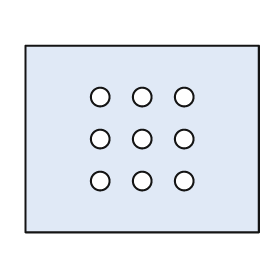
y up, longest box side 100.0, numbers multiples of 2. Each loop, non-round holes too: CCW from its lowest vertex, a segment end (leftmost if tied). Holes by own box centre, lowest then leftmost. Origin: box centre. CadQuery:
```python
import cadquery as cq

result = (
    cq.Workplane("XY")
    .moveTo(-50.0, -40.0)
    .lineTo(50.0, -40.0)
    .lineTo(50.0, 40.0)
    .lineTo(-50.0, 40.0)
    .close()
    .moveTo(-18.0, -18.0)
    .circle(4.0)
    .moveTo(0.0, -18.0)
    .circle(4.0)
    .moveTo(18.0, -18.0)
    .circle(4.0)
    .moveTo(-18.0, 0.0)
    .circle(4.0)
    .moveTo(0.0, 0.0)
    .circle(4.0)
    .moveTo(18.0, 0.0)
    .circle(4.0)
    .moveTo(-18.0, 18.0)
    .circle(4.0)
    .moveTo(0.0, 18.0)
    .circle(4.0)
    .moveTo(18.0, 18.0)
    .circle(4.0)
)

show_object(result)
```